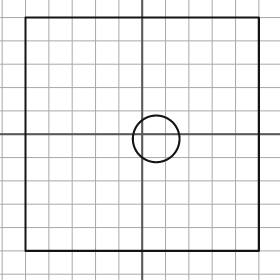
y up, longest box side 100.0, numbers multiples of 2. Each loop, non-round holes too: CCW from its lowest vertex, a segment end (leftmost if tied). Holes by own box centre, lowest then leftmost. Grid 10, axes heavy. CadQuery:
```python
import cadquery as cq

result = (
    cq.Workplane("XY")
    .moveTo(-50.0, -50.0)
    .lineTo(50.0, -50.0)
    .lineTo(50.0, 50.0)
    .lineTo(-50.0, 50.0)
    .close()
    .moveTo(6.0, -2.0)
    .circle(10.0)
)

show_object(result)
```